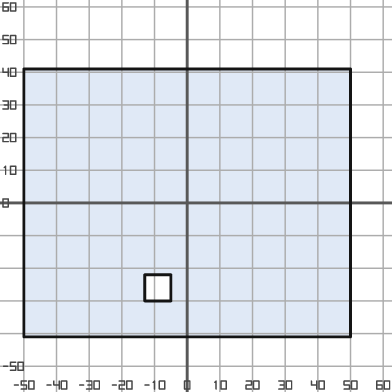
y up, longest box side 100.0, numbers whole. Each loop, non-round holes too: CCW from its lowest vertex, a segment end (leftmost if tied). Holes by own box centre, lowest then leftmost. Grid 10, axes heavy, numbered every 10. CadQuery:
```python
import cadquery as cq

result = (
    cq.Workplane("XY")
    .moveTo(-50.0, -41.0)
    .lineTo(50.0, -41.0)
    .lineTo(50.0, 41.0)
    .lineTo(-50.0, 41.0)
    .close()
    .moveTo(-13.0, -30.0)
    .lineTo(-5.0, -30.0)
    .lineTo(-5.0, -22.0)
    .lineTo(-13.0, -22.0)
    .close()
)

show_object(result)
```